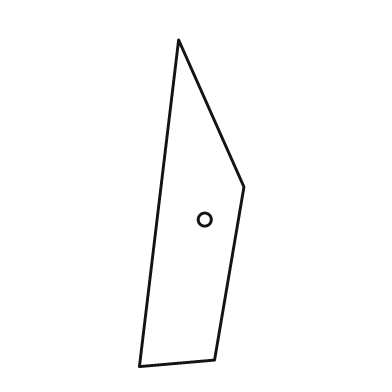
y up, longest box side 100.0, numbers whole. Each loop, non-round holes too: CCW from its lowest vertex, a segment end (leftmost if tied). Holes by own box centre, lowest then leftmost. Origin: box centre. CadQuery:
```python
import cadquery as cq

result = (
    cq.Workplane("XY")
    .moveTo(-16.0, -50.0)
    .lineTo(7.0, -48.0)
    .lineTo(16.0, 5.0)
    .lineTo(-4.0, 50.0)
    .close()
    .moveTo(4.0, -5.0)
    .circle(2.0)
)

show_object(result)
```